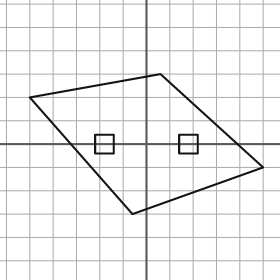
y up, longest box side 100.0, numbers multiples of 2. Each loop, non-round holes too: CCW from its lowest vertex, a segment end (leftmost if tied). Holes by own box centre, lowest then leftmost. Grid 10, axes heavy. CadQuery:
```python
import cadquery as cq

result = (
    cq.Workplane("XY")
    .moveTo(-6.0, -30.0)
    .lineTo(50.0, -10.0)
    .lineTo(6.0, 30.0)
    .lineTo(-50.0, 20.0)
    .close()
    .moveTo(-22.0, -4.0)
    .lineTo(-14.0, -4.0)
    .lineTo(-14.0, 4.0)
    .lineTo(-22.0, 4.0)
    .close()
    .moveTo(14.0, -4.0)
    .lineTo(22.0, -4.0)
    .lineTo(22.0, 4.0)
    .lineTo(14.0, 4.0)
    .close()
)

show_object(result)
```